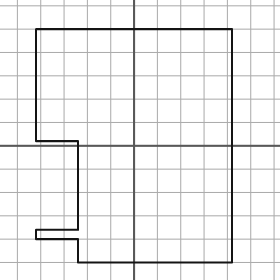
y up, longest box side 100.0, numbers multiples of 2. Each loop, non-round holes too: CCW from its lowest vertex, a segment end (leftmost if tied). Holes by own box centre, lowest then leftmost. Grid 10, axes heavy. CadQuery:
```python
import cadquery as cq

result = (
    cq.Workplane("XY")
    .moveTo(-24.0, -50.0)
    .lineTo(42.0, -50.0)
    .lineTo(42.0, 50.0)
    .lineTo(-42.0, 50.0)
    .lineTo(-42.0, 2.0)
    .lineTo(-24.0, 2.0)
    .lineTo(-24.0, -36.0)
    .lineTo(-42.0, -36.0)
    .lineTo(-42.0, -40.0)
    .lineTo(-24.0, -40.0)
    .close()
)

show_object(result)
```